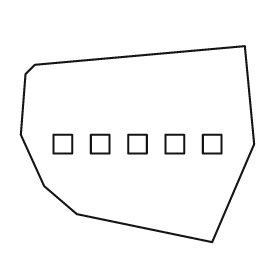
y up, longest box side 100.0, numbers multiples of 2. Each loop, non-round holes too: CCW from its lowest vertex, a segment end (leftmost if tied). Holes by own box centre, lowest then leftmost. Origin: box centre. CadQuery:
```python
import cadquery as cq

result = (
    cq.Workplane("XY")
    .moveTo(32.0, -42.0)
    .lineTo(50.0, 0.0)
    .lineTo(46.0, 42.0)
    .lineTo(-44.0, 34.0)
    .lineTo(-48.0, 30.0)
    .lineTo(-50.0, 4.0)
    .lineTo(-40.0, -18.0)
    .lineTo(-26.0, -30.0)
    .close()
    .moveTo(-36.0, -4.0)
    .lineTo(-28.0, -4.0)
    .lineTo(-28.0, 4.0)
    .lineTo(-36.0, 4.0)
    .close()
    .moveTo(-20.0, -4.0)
    .lineTo(-12.0, -4.0)
    .lineTo(-12.0, 4.0)
    .lineTo(-20.0, 4.0)
    .close()
    .moveTo(-4.0, -4.0)
    .lineTo(4.0, -4.0)
    .lineTo(4.0, 4.0)
    .lineTo(-4.0, 4.0)
    .close()
    .moveTo(12.0, -4.0)
    .lineTo(20.0, -4.0)
    .lineTo(20.0, 4.0)
    .lineTo(12.0, 4.0)
    .close()
    .moveTo(28.0, -4.0)
    .lineTo(36.0, -4.0)
    .lineTo(36.0, 4.0)
    .lineTo(28.0, 4.0)
    .close()
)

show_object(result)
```